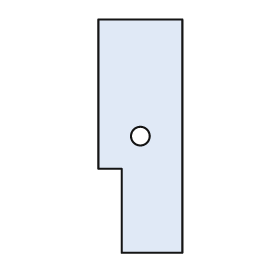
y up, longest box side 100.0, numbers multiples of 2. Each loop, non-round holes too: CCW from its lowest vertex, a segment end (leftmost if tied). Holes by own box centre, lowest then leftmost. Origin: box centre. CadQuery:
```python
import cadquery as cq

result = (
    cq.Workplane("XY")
    .moveTo(-8.0, -50.0)
    .lineTo(18.0, -50.0)
    .lineTo(18.0, 50.0)
    .lineTo(-18.0, 50.0)
    .lineTo(-18.0, -14.0)
    .lineTo(-8.0, -14.0)
    .close()
    .moveTo(0.0, 0.0)
    .circle(4.0)
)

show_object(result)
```